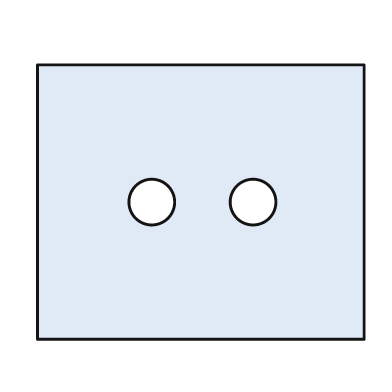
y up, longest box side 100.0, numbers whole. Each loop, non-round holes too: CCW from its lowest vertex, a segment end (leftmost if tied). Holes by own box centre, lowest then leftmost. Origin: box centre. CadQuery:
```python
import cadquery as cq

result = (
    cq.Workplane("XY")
    .moveTo(-50.0, -42.0)
    .lineTo(50.0, -42.0)
    .lineTo(50.0, 42.0)
    .lineTo(-50.0, 42.0)
    .close()
    .moveTo(-15.0, 0.0)
    .circle(7.0)
    .moveTo(16.0, 0.0)
    .circle(7.0)
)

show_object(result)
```